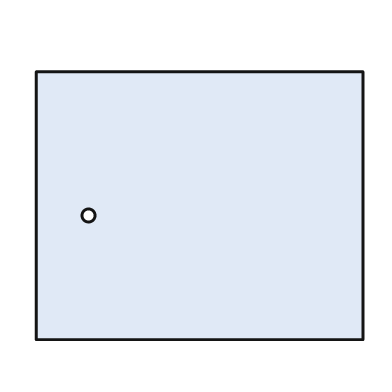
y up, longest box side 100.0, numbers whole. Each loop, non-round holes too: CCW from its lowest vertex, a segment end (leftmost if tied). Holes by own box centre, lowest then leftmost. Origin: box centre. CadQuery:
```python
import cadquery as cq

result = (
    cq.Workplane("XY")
    .moveTo(-50.0, -41.0)
    .lineTo(50.0, -41.0)
    .lineTo(50.0, 41.0)
    .lineTo(-50.0, 41.0)
    .close()
    .moveTo(-34.0, -3.0)
    .circle(2.0)
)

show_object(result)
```